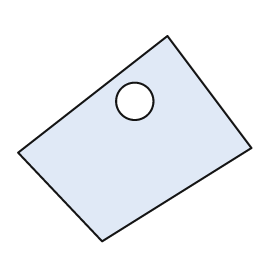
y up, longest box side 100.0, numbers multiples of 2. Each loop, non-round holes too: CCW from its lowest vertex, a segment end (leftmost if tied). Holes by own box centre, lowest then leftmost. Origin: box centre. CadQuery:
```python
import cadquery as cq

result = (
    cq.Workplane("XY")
    .moveTo(-14.0, -44.0)
    .lineTo(50.0, -4.0)
    .lineTo(14.0, 44.0)
    .lineTo(-50.0, -6.0)
    .close()
    .moveTo(0.0, 16.0)
    .circle(8.0)
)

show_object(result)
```